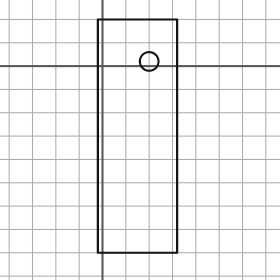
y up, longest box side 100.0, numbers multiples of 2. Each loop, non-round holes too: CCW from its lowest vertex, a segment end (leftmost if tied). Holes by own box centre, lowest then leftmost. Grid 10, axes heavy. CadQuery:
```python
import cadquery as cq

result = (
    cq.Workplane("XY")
    .moveTo(-2.0, -80.0)
    .lineTo(32.0, -80.0)
    .lineTo(32.0, 20.0)
    .lineTo(-2.0, 20.0)
    .close()
    .moveTo(20.0, 2.0)
    .circle(4.0)
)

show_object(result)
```